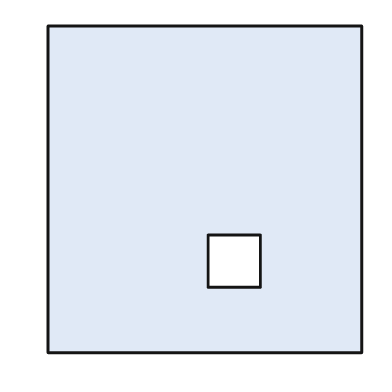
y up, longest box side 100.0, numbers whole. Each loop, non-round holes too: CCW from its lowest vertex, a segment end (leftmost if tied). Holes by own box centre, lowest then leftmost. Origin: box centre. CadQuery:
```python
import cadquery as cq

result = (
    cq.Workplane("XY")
    .moveTo(-48.0, -50.0)
    .lineTo(48.0, -50.0)
    .lineTo(48.0, 50.0)
    .lineTo(-48.0, 50.0)
    .close()
    .moveTo(1.0, -30.0)
    .lineTo(17.0, -30.0)
    .lineTo(17.0, -14.0)
    .lineTo(1.0, -14.0)
    .close()
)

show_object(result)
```